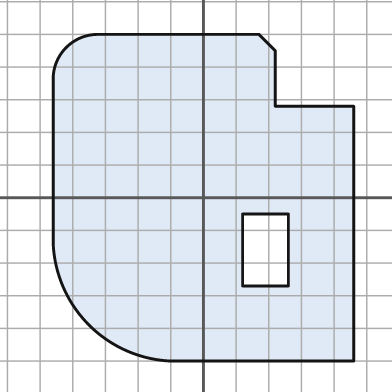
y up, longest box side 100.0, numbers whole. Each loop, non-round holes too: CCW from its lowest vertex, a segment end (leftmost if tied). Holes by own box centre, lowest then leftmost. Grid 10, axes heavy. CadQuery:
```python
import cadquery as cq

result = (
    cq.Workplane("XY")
    .moveTo(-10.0, -50.0)
    .lineTo(46.0, -50.0)
    .lineTo(46.0, 28.0)
    .lineTo(22.0, 28.0)
    .lineTo(22.0, 45.0)
    .lineTo(17.0, 50.0)
    .lineTo(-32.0, 50.0)
    .threePointArc((-42.0, 46.0), (-46.0, 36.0))
    .lineTo(-46.0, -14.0)
    .threePointArc((-35.0, -39.0), (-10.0, -50.0))
    .close()
    .moveTo(12.0, -27.0)
    .lineTo(26.0, -27.0)
    .lineTo(26.0, -5.0)
    .lineTo(12.0, -5.0)
    .close()
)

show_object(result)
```